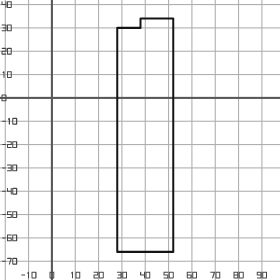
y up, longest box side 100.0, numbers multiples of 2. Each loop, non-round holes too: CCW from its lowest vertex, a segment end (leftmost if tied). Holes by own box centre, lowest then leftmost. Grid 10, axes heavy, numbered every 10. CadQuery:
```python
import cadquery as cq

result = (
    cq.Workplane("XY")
    .moveTo(28.0, -66.0)
    .lineTo(52.0, -66.0)
    .lineTo(52.0, 34.0)
    .lineTo(38.0, 34.0)
    .lineTo(38.0, 30.0)
    .lineTo(28.0, 30.0)
    .close()
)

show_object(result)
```